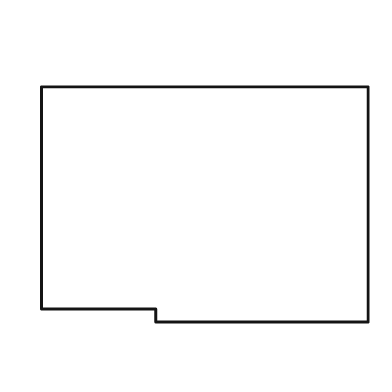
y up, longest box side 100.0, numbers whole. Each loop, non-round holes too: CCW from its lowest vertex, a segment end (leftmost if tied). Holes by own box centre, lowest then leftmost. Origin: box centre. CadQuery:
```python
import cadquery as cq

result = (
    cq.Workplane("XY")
    .moveTo(-15.0, -36.0)
    .lineTo(50.0, -36.0)
    .lineTo(50.0, 36.0)
    .lineTo(-50.0, 36.0)
    .lineTo(-50.0, -32.0)
    .lineTo(-15.0, -32.0)
    .close()
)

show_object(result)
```